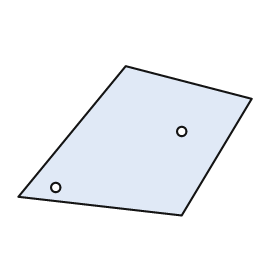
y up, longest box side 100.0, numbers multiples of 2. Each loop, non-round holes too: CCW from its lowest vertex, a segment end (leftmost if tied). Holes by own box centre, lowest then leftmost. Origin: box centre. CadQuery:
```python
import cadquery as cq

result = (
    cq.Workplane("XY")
    .moveTo(20.0, -32.0)
    .lineTo(50.0, 18.0)
    .lineTo(-4.0, 32.0)
    .lineTo(-50.0, -24.0)
    .close()
    .moveTo(-34.0, -20.0)
    .circle(2.0)
    .moveTo(20.0, 4.0)
    .circle(2.0)
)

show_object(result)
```